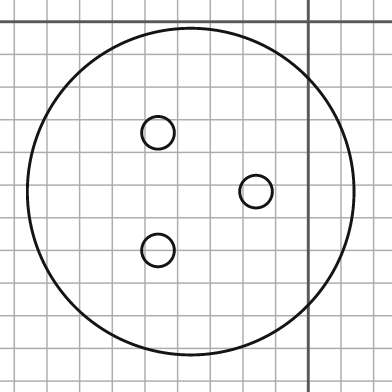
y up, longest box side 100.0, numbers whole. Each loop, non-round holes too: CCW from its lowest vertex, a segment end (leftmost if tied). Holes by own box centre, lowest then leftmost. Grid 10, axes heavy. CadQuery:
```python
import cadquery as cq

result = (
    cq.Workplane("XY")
    .moveTo(-36.0, -52.0)
    .circle(50.0)
    .moveTo(-46.0, -70.0)
    .circle(5.0)
    .moveTo(-16.0, -52.0)
    .circle(5.0)
    .moveTo(-46.0, -34.0)
    .circle(5.0)
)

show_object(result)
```